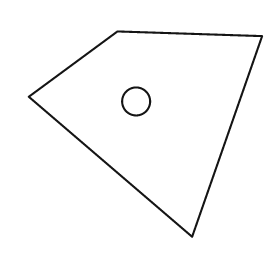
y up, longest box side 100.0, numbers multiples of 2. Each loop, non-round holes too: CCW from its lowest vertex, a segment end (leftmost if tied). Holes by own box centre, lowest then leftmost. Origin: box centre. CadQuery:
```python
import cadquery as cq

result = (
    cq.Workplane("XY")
    .moveTo(20.0, -44.0)
    .lineTo(50.0, 42.0)
    .lineTo(-12.0, 44.0)
    .lineTo(-50.0, 16.0)
    .close()
    .moveTo(-4.0, 14.0)
    .circle(6.0)
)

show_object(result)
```